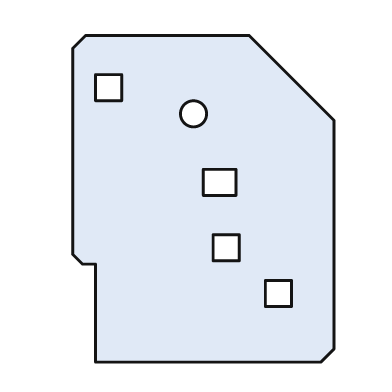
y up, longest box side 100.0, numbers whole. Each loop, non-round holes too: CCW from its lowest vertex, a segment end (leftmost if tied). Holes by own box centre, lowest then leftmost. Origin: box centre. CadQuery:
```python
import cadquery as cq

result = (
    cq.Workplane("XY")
    .moveTo(-33.0, -50.0)
    .lineTo(36.0, -50.0)
    .lineTo(40.0, -46.0)
    .lineTo(40.0, 24.0)
    .lineTo(14.0, 50.0)
    .lineTo(-36.0, 50.0)
    .lineTo(-40.0, 46.0)
    .lineTo(-40.0, -17.0)
    .lineTo(-37.0, -20.0)
    .lineTo(-33.0, -20.0)
    .close()
    .moveTo(19.0, -33.0)
    .lineTo(27.0, -33.0)
    .lineTo(27.0, -25.0)
    .lineTo(19.0, -25.0)
    .close()
    .moveTo(3.0, -19.0)
    .lineTo(11.0, -19.0)
    .lineTo(11.0, -11.0)
    .lineTo(3.0, -11.0)
    .close()
    .moveTo(0.0, 1.0)
    .lineTo(10.0, 1.0)
    .lineTo(10.0, 9.0)
    .lineTo(0.0, 9.0)
    .close()
    .moveTo(-3.0, 26.0)
    .circle(4.0)
    .moveTo(-33.0, 30.0)
    .lineTo(-25.0, 30.0)
    .lineTo(-25.0, 38.0)
    .lineTo(-33.0, 38.0)
    .close()
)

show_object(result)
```